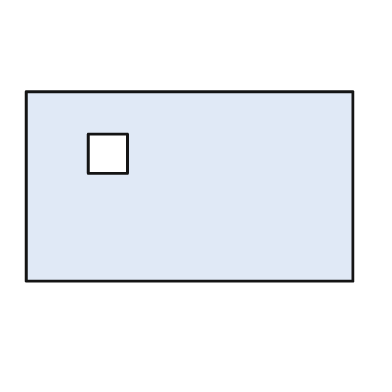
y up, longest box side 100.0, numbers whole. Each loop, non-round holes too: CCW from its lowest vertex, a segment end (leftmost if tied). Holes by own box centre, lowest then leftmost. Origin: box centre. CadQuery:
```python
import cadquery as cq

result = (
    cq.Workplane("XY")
    .moveTo(-50.0, -29.0)
    .lineTo(50.0, -29.0)
    .lineTo(50.0, 29.0)
    .lineTo(-50.0, 29.0)
    .close()
    .moveTo(-31.0, 4.0)
    .lineTo(-19.0, 4.0)
    .lineTo(-19.0, 16.0)
    .lineTo(-31.0, 16.0)
    .close()
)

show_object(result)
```